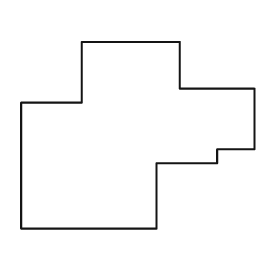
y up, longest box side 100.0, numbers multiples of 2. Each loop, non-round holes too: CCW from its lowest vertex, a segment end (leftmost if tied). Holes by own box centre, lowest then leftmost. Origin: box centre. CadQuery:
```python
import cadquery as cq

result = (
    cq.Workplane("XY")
    .moveTo(-50.0, -40.0)
    .lineTo(8.0, -40.0)
    .lineTo(8.0, -12.0)
    .lineTo(34.0, -12.0)
    .lineTo(34.0, -6.0)
    .lineTo(50.0, -6.0)
    .lineTo(50.0, 20.0)
    .lineTo(18.0, 20.0)
    .lineTo(18.0, 40.0)
    .lineTo(-24.0, 40.0)
    .lineTo(-24.0, 14.0)
    .lineTo(-50.0, 14.0)
    .close()
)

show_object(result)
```